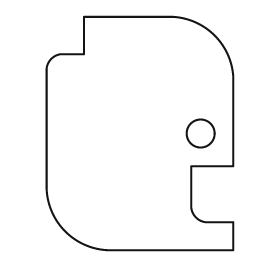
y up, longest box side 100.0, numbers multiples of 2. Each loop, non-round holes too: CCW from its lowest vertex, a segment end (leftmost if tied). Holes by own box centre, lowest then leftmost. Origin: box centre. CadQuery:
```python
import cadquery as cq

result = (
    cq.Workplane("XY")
    .moveTo(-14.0, -50.0)
    .lineTo(40.0, -50.0)
    .lineTo(40.0, -38.0)
    .lineTo(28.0, -38.0)
    .threePointArc((24.0, -36.0), (22.0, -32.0))
    .lineTo(22.0, -14.0)
    .lineTo(40.0, -14.0)
    .lineTo(40.0, 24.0)
    .threePointArc((32.0, 42.0), (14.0, 50.0))
    .lineTo(-24.0, 50.0)
    .lineTo(-24.0, 34.0)
    .lineTo(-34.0, 34.0)
    .threePointArc((-38.0, 32.0), (-40.0, 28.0))
    .lineTo(-40.0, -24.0)
    .threePointArc((-32.0, -42.0), (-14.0, -50.0))
    .close()
    .moveTo(26.0, 0.0)
    .circle(6.0)
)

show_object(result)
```